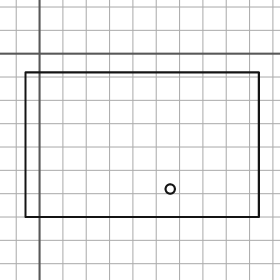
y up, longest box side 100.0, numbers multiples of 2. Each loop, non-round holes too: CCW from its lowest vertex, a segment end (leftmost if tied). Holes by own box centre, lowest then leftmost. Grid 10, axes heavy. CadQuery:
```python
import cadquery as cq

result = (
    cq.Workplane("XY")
    .moveTo(-6.0, -70.0)
    .lineTo(94.0, -70.0)
    .lineTo(94.0, -8.0)
    .lineTo(-6.0, -8.0)
    .close()
    .moveTo(56.0, -58.0)
    .circle(2.0)
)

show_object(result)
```